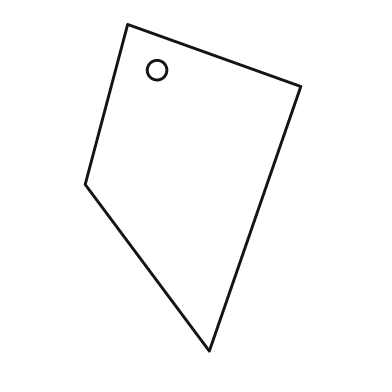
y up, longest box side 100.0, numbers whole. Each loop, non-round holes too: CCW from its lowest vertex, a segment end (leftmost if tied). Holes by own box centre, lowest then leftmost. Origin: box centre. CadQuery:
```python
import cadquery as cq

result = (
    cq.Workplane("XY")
    .moveTo(5.0, -50.0)
    .lineTo(33.0, 31.0)
    .lineTo(-20.0, 50.0)
    .lineTo(-33.0, 1.0)
    .close()
    .moveTo(-11.0, 36.0)
    .circle(3.0)
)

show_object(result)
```